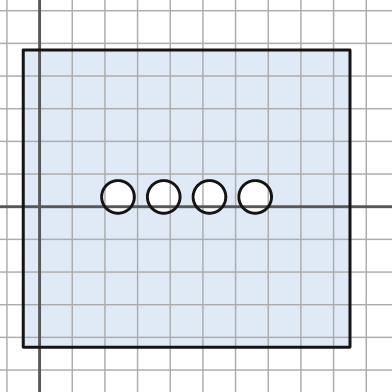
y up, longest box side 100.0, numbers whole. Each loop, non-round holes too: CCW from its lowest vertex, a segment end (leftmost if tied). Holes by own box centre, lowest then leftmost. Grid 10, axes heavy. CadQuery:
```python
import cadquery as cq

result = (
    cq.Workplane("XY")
    .moveTo(-5.0, -43.0)
    .lineTo(95.0, -43.0)
    .lineTo(95.0, 48.0)
    .lineTo(-5.0, 48.0)
    .close()
    .moveTo(24.0, 3.0)
    .circle(5.0)
    .moveTo(38.0, 3.0)
    .circle(5.0)
    .moveTo(52.0, 3.0)
    .circle(5.0)
    .moveTo(66.0, 3.0)
    .circle(5.0)
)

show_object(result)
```